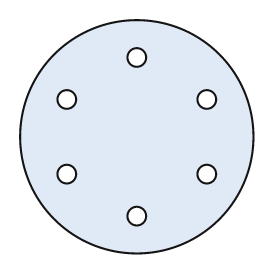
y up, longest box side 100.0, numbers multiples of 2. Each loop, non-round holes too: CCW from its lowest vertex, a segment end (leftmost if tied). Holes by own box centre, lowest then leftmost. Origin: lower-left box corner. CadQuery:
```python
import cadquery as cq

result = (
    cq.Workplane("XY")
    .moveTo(50.0, 50.0)
    .circle(50.0)
    .moveTo(50.0, 16.0)
    .circle(4.0)
    .moveTo(20.0, 34.0)
    .circle(4.0)
    .moveTo(80.0, 34.0)
    .circle(4.0)
    .moveTo(20.0, 66.0)
    .circle(4.0)
    .moveTo(80.0, 66.0)
    .circle(4.0)
    .moveTo(50.0, 84.0)
    .circle(4.0)
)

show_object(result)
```